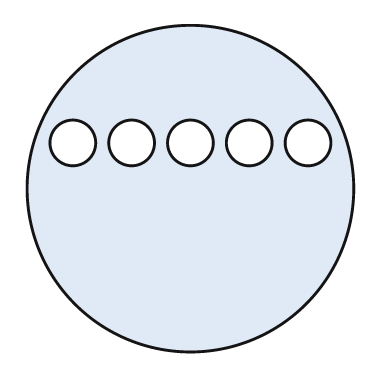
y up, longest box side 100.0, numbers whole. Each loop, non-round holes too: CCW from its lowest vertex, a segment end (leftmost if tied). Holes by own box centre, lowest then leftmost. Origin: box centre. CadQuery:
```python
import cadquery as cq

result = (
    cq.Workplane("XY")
    .moveTo(0.0, 0.0)
    .circle(50.0)
    .moveTo(-36.0, 14.0)
    .circle(7.0)
    .moveTo(-18.0, 14.0)
    .circle(7.0)
    .moveTo(0.0, 14.0)
    .circle(7.0)
    .moveTo(18.0, 14.0)
    .circle(7.0)
    .moveTo(36.0, 14.0)
    .circle(7.0)
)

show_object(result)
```